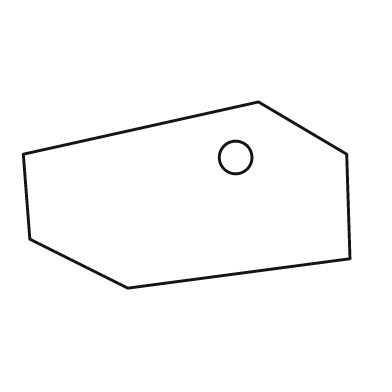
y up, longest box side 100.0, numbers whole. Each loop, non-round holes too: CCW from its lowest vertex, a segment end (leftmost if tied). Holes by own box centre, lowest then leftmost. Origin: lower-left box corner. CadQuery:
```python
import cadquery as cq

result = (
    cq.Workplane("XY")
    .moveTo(32.0, 0.0)
    .lineTo(100.0, 9.0)
    .lineTo(99.0, 41.0)
    .lineTo(72.0, 57.0)
    .lineTo(0.0, 41.0)
    .lineTo(2.0, 15.0)
    .close()
    .moveTo(65.0, 40.0)
    .circle(5.0)
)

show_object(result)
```